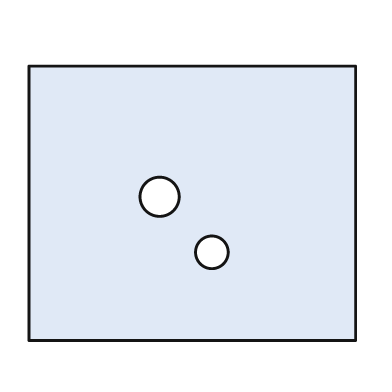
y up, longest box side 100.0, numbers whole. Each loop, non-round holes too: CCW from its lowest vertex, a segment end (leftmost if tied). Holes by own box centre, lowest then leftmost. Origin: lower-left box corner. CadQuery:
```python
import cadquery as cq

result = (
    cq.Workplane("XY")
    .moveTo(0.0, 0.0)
    .lineTo(100.0, 0.0)
    .lineTo(100.0, 84.0)
    .lineTo(0.0, 84.0)
    .close()
    .moveTo(56.0, 27.0)
    .circle(5.0)
    .moveTo(40.0, 44.0)
    .circle(6.0)
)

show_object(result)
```